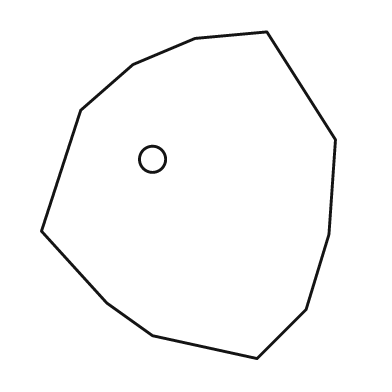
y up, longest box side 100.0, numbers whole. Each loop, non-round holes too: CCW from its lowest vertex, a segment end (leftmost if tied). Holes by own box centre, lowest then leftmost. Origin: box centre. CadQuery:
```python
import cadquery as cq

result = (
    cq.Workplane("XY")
    .moveTo(21.0, -50.0)
    .lineTo(36.0, -35.0)
    .lineTo(43.0, -12.0)
    .lineTo(45.0, 17.0)
    .lineTo(24.0, 50.0)
    .lineTo(2.0, 48.0)
    .lineTo(-17.0, 40.0)
    .lineTo(-33.0, 26.0)
    .lineTo(-45.0, -11.0)
    .lineTo(-25.0, -33.0)
    .lineTo(-11.0, -43.0)
    .close()
    .moveTo(-11.0, 11.0)
    .circle(4.0)
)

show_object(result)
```